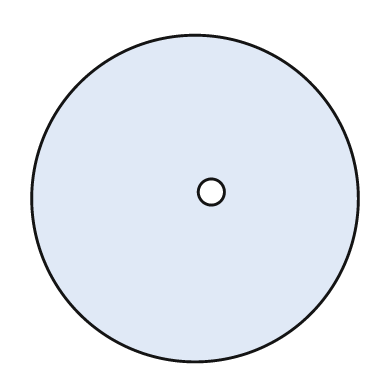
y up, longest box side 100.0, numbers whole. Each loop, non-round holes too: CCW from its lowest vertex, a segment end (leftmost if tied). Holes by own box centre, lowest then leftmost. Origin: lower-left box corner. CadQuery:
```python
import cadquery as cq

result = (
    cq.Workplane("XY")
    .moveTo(50.0, 50.0)
    .circle(50.0)
    .moveTo(55.0, 52.0)
    .circle(4.0)
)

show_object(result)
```